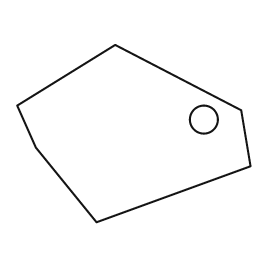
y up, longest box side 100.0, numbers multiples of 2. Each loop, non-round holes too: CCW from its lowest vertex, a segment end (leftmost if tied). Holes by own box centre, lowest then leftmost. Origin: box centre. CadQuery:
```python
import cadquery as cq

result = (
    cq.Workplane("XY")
    .moveTo(-16.0, -38.0)
    .lineTo(50.0, -14.0)
    .lineTo(46.0, 10.0)
    .lineTo(-8.0, 38.0)
    .lineTo(-50.0, 12.0)
    .lineTo(-42.0, -6.0)
    .close()
    .moveTo(30.0, 6.0)
    .circle(6.0)
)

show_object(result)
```